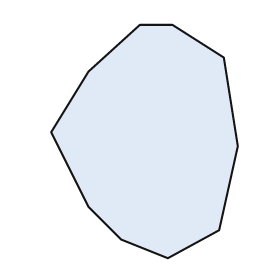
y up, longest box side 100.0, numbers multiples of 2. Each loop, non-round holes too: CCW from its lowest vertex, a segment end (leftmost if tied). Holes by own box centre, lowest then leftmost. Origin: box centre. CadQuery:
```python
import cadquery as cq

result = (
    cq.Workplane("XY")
    .moveTo(10.0, -50.0)
    .lineTo(32.0, -38.0)
    .lineTo(40.0, -2.0)
    .lineTo(34.0, 36.0)
    .lineTo(12.0, 50.0)
    .lineTo(-2.0, 50.0)
    .lineTo(-24.0, 30.0)
    .lineTo(-40.0, 4.0)
    .lineTo(-24.0, -28.0)
    .lineTo(-10.0, -42.0)
    .close()
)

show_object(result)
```